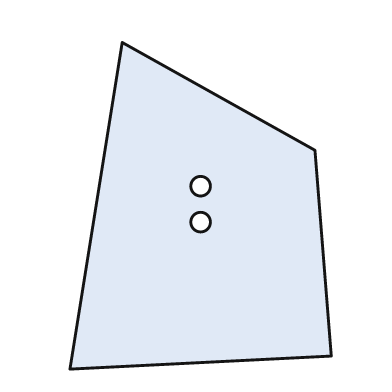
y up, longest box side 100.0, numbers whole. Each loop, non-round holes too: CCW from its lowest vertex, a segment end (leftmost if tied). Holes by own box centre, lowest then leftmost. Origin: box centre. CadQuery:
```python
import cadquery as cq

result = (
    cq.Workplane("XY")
    .moveTo(-40.0, -50.0)
    .lineTo(40.0, -46.0)
    .lineTo(35.0, 17.0)
    .lineTo(-24.0, 50.0)
    .close()
    .moveTo(0.0, -5.0)
    .circle(3.0)
    .moveTo(0.0, 6.0)
    .circle(3.0)
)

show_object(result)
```